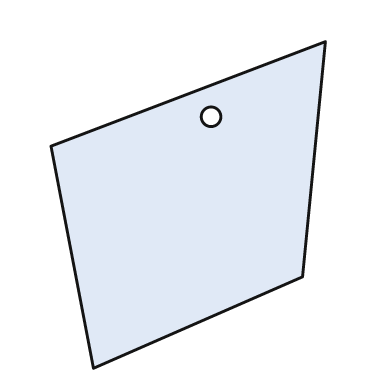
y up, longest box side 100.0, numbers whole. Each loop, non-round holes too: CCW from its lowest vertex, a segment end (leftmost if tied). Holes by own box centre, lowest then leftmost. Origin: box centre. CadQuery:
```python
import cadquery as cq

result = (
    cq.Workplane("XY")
    .moveTo(-29.0, -50.0)
    .lineTo(35.0, -22.0)
    .lineTo(42.0, 50.0)
    .lineTo(-42.0, 18.0)
    .close()
    .moveTo(7.0, 27.0)
    .circle(3.0)
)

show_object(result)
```